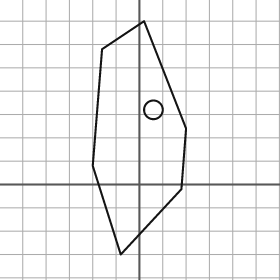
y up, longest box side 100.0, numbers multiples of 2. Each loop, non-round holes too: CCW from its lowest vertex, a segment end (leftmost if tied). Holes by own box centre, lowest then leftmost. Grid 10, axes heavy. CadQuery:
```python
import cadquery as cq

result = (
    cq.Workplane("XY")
    .moveTo(-8.0, -30.0)
    .lineTo(18.0, -2.0)
    .lineTo(20.0, 24.0)
    .lineTo(2.0, 70.0)
    .lineTo(-16.0, 58.0)
    .lineTo(-20.0, 8.0)
    .close()
    .moveTo(6.0, 32.0)
    .circle(4.0)
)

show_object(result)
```